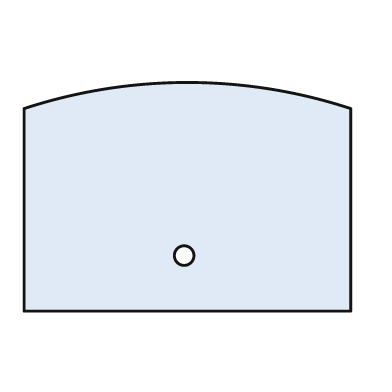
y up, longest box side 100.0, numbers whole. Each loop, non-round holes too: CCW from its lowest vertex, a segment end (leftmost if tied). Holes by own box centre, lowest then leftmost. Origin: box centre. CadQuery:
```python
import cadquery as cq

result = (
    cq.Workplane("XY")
    .moveTo(-50.0, -35.0)
    .lineTo(50.0, -35.0)
    .lineTo(50.0, 27.0)
    .threePointArc((0.0, 35.0), (-50.0, 27.0))
    .close()
    .moveTo(-1.0, -18.0)
    .circle(3.0)
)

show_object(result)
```